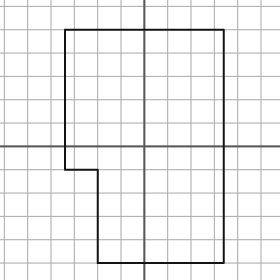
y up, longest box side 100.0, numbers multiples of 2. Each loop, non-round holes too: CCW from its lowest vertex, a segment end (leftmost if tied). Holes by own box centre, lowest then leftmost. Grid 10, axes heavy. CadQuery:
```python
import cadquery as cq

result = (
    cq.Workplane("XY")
    .moveTo(-20.0, -50.0)
    .lineTo(34.0, -50.0)
    .lineTo(34.0, 50.0)
    .lineTo(-34.0, 50.0)
    .lineTo(-34.0, -10.0)
    .lineTo(-20.0, -10.0)
    .close()
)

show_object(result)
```